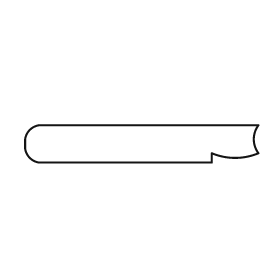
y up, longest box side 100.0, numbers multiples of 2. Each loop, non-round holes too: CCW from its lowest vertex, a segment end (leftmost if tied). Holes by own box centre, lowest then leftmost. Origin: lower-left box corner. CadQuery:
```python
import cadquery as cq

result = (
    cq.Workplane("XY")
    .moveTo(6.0, 0.0)
    .lineTo(80.0, 0.0)
    .lineTo(80.0, 4.0)
    .threePointArc((90.0, 2.0), (100.0, 4.0))
    .threePointArc((98.0, 10.0), (100.0, 16.0))
    .lineTo(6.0, 16.0)
    .threePointArc((2.0, 14.0), (0.0, 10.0))
    .lineTo(0.0, 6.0)
    .threePointArc((2.0, 2.0), (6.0, 0.0))
    .close()
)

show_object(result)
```